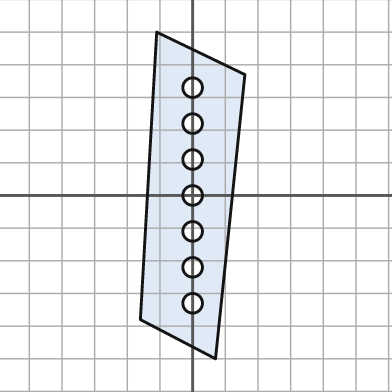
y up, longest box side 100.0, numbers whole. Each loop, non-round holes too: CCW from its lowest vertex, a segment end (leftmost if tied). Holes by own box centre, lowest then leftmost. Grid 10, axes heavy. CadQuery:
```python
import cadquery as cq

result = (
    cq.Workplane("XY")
    .moveTo(7.0, -50.0)
    .lineTo(16.0, 37.0)
    .lineTo(-11.0, 50.0)
    .lineTo(-16.0, -38.0)
    .close()
    .moveTo(0.0, -33.0)
    .circle(3.0)
    .moveTo(0.0, -22.0)
    .circle(3.0)
    .moveTo(0.0, -11.0)
    .circle(3.0)
    .moveTo(0.0, 0.0)
    .circle(3.0)
    .moveTo(0.0, 11.0)
    .circle(3.0)
    .moveTo(0.0, 22.0)
    .circle(3.0)
    .moveTo(0.0, 33.0)
    .circle(3.0)
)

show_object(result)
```